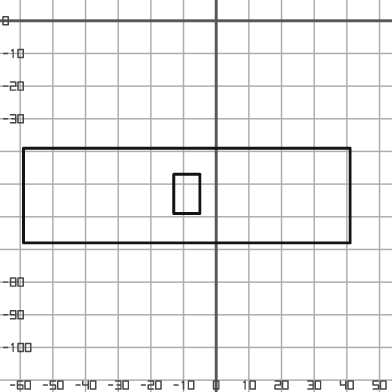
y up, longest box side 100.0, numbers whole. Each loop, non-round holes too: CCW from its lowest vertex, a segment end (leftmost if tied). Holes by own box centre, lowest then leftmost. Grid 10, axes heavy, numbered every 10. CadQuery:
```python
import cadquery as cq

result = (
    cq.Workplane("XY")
    .moveTo(-59.0, -68.0)
    .lineTo(41.0, -68.0)
    .lineTo(41.0, -39.0)
    .lineTo(-59.0, -39.0)
    .close()
    .moveTo(-13.0, -59.0)
    .lineTo(-5.0, -59.0)
    .lineTo(-5.0, -47.0)
    .lineTo(-13.0, -47.0)
    .close()
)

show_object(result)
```